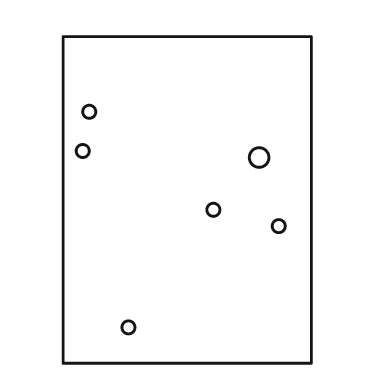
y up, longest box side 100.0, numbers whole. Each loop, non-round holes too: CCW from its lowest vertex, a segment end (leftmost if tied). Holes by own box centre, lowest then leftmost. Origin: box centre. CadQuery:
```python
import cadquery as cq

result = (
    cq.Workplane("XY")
    .moveTo(-38.0, -50.0)
    .lineTo(38.0, -50.0)
    .lineTo(38.0, 50.0)
    .lineTo(-38.0, 50.0)
    .close()
    .moveTo(-18.0, -39.0)
    .circle(2.0)
    .moveTo(28.0, -8.0)
    .circle(2.0)
    .moveTo(8.0, -3.0)
    .circle(2.0)
    .moveTo(22.0, 13.0)
    .circle(3.0)
    .moveTo(-32.0, 15.0)
    .circle(2.0)
    .moveTo(-30.0, 27.0)
    .circle(2.0)
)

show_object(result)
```